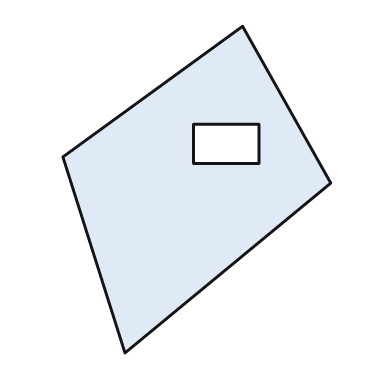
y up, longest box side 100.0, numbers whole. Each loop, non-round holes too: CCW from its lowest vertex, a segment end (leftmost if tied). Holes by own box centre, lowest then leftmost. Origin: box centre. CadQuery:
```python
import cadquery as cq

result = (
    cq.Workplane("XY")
    .moveTo(-22.0, -50.0)
    .lineTo(41.0, 2.0)
    .lineTo(14.0, 50.0)
    .lineTo(-41.0, 10.0)
    .close()
    .moveTo(-1.0, 8.0)
    .lineTo(19.0, 8.0)
    .lineTo(19.0, 20.0)
    .lineTo(-1.0, 20.0)
    .close()
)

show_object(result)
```